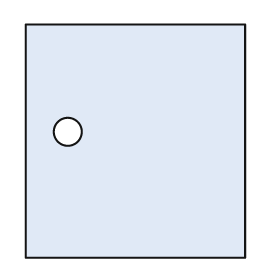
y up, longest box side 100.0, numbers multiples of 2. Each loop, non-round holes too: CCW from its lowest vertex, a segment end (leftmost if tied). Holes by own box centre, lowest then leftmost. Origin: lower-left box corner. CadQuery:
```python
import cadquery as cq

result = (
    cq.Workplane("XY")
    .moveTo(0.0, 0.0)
    .lineTo(94.0, 0.0)
    .lineTo(94.0, 100.0)
    .lineTo(0.0, 100.0)
    .close()
    .moveTo(18.0, 54.0)
    .circle(6.0)
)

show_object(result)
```